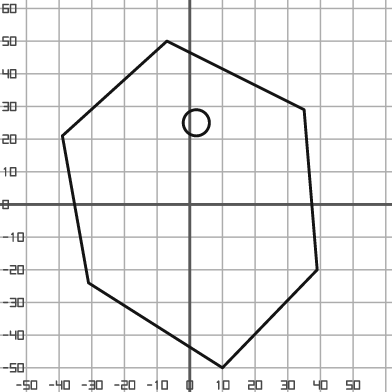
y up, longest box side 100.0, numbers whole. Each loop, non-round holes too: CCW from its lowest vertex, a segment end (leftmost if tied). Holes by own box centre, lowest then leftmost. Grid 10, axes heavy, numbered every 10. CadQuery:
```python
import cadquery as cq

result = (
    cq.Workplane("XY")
    .moveTo(10.0, -50.0)
    .lineTo(39.0, -20.0)
    .lineTo(35.0, 29.0)
    .lineTo(-7.0, 50.0)
    .lineTo(-39.0, 21.0)
    .lineTo(-31.0, -24.0)
    .close()
    .moveTo(2.0, 25.0)
    .circle(4.0)
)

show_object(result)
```